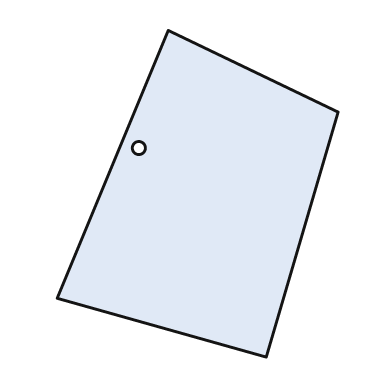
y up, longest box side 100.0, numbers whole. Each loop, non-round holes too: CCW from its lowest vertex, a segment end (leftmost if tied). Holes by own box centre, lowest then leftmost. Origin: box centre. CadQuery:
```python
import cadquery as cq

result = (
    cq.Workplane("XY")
    .moveTo(21.0, -50.0)
    .lineTo(43.0, 25.0)
    .lineTo(-9.0, 50.0)
    .lineTo(-43.0, -32.0)
    .close()
    .moveTo(-18.0, 14.0)
    .circle(2.0)
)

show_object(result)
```